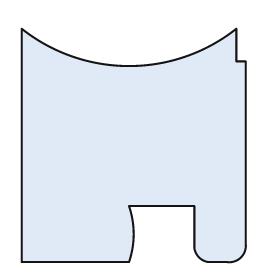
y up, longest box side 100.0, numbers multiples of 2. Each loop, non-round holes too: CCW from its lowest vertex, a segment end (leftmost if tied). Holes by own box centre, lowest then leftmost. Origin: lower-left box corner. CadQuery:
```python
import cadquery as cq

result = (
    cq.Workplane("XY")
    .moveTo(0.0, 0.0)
    .lineTo(46.0, 0.0)
    .threePointArc((48.0, 12.0), (46.0, 24.0))
    .lineTo(74.0, 24.0)
    .lineTo(74.0, 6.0)
    .threePointArc((76.0, 2.0), (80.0, 0.0))
    .lineTo(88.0, 0.0)
    .threePointArc((94.0, 2.0), (96.0, 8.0))
    .lineTo(96.0, 86.0)
    .lineTo(92.0, 86.0)
    .lineTo(92.0, 100.0)
    .threePointArc((46.0, 84.0), (0.0, 100.0))
    .close()
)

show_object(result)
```